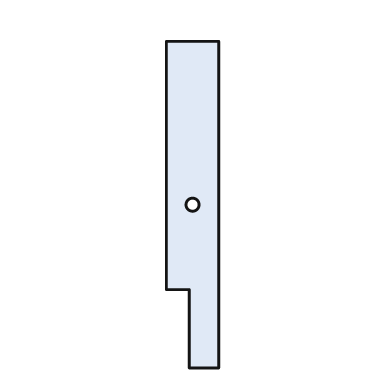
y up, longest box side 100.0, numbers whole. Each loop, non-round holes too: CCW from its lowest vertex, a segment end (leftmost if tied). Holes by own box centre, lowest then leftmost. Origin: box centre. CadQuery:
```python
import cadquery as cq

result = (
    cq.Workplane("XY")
    .moveTo(-1.0, -50.0)
    .lineTo(8.0, -50.0)
    .lineTo(8.0, 50.0)
    .lineTo(-8.0, 50.0)
    .lineTo(-8.0, -26.0)
    .lineTo(-1.0, -26.0)
    .close()
    .moveTo(0.0, 0.0)
    .circle(2.0)
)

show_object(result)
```